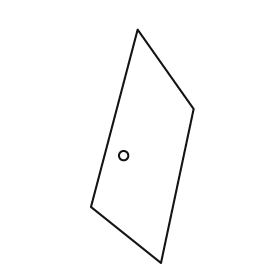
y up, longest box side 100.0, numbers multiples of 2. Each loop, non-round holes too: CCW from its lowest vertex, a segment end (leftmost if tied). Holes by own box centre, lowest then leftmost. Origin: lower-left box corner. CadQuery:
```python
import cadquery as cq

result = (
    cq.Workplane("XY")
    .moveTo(30.0, 0.0)
    .lineTo(44.0, 66.0)
    .lineTo(20.0, 100.0)
    .lineTo(0.0, 24.0)
    .close()
    .moveTo(14.0, 46.0)
    .circle(2.0)
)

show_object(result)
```